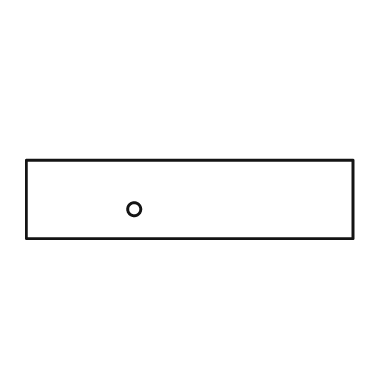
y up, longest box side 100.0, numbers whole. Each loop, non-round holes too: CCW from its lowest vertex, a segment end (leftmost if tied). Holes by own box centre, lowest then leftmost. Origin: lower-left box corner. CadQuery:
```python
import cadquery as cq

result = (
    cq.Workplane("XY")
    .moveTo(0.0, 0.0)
    .lineTo(100.0, 0.0)
    .lineTo(100.0, 24.0)
    .lineTo(0.0, 24.0)
    .close()
    .moveTo(33.0, 9.0)
    .circle(2.0)
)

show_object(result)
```